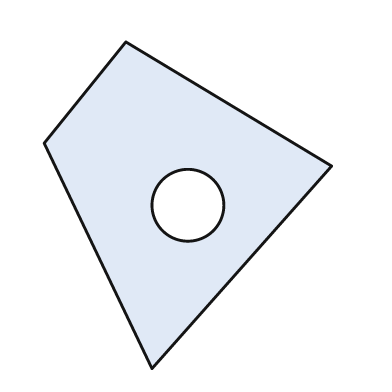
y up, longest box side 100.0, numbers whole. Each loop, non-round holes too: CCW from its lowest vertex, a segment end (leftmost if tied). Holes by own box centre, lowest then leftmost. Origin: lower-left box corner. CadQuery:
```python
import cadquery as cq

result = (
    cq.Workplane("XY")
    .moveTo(33.0, 0.0)
    .lineTo(88.0, 62.0)
    .lineTo(25.0, 100.0)
    .lineTo(0.0, 69.0)
    .close()
    .moveTo(44.0, 50.0)
    .circle(11.0)
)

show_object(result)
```